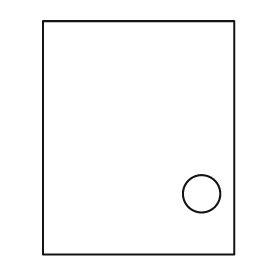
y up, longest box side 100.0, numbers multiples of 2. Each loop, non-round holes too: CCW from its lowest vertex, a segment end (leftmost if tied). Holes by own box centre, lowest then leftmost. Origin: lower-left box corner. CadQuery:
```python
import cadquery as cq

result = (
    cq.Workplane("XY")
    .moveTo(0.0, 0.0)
    .lineTo(82.0, 0.0)
    .lineTo(82.0, 100.0)
    .lineTo(0.0, 100.0)
    .close()
    .moveTo(68.0, 26.0)
    .circle(8.0)
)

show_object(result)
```